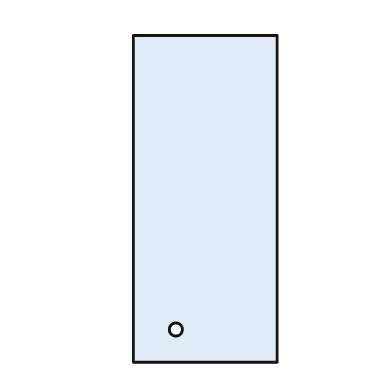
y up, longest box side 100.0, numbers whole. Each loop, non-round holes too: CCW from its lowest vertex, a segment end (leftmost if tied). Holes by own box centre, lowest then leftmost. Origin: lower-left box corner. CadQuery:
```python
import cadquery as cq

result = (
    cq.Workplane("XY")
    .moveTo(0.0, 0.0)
    .lineTo(44.0, 0.0)
    .lineTo(44.0, 100.0)
    .lineTo(0.0, 100.0)
    .close()
    .moveTo(13.0, 10.0)
    .circle(2.0)
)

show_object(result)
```